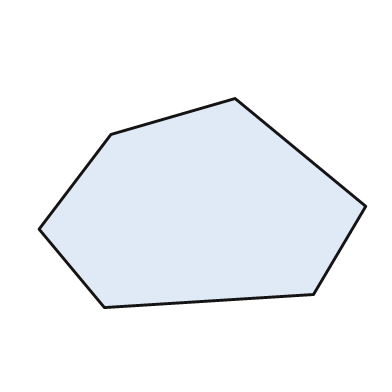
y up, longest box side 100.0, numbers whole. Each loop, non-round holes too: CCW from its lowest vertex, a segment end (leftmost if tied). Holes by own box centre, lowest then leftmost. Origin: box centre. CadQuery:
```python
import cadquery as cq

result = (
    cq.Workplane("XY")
    .moveTo(-30.0, -32.0)
    .lineTo(34.0, -28.0)
    .lineTo(50.0, -1.0)
    .lineTo(10.0, 32.0)
    .lineTo(-28.0, 21.0)
    .lineTo(-50.0, -8.0)
    .close()
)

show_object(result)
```